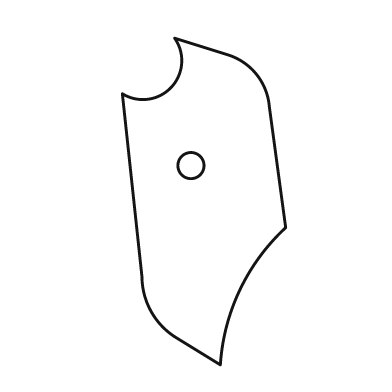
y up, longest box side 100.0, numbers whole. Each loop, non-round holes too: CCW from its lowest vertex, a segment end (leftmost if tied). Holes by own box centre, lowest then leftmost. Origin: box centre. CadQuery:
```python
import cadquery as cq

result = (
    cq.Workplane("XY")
    .moveTo(5.0, -50.0)
    .threePointArc((11.0, -27.0), (25.0, -8.0))
    .lineTo(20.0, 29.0)
    .threePointArc((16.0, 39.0), (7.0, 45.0))
    .lineTo(-9.0, 50.0)
    .threePointArc((-10.0, 35.0), (-25.0, 33.0))
    .lineTo(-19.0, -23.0)
    .threePointArc((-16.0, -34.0), (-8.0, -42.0))
    .close()
    .moveTo(-4.0, 11.0)
    .circle(4.0)
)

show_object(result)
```